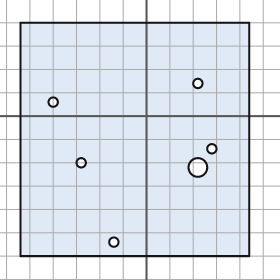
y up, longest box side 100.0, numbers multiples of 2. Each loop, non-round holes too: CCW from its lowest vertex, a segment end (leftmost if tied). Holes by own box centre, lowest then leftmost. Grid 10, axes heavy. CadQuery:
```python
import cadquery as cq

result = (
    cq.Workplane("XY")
    .moveTo(-54.0, -60.0)
    .lineTo(44.0, -60.0)
    .lineTo(44.0, 40.0)
    .lineTo(-54.0, 40.0)
    .close()
    .moveTo(-14.0, -54.0)
    .circle(2.0)
    .moveTo(22.0, -22.0)
    .circle(4.0)
    .moveTo(-28.0, -20.0)
    .circle(2.0)
    .moveTo(28.0, -14.0)
    .circle(2.0)
    .moveTo(-40.0, 6.0)
    .circle(2.0)
    .moveTo(22.0, 14.0)
    .circle(2.0)
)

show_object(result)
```